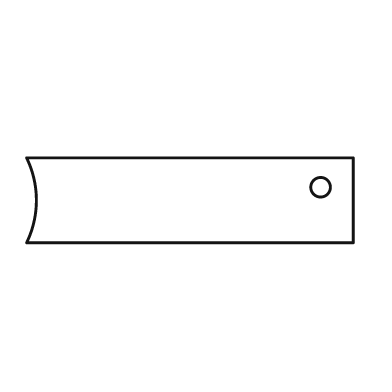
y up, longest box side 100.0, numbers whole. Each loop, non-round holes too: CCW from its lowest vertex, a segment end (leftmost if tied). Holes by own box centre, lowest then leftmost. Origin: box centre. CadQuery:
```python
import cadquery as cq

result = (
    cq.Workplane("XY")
    .moveTo(-50.0, -13.0)
    .lineTo(50.0, -13.0)
    .lineTo(50.0, 13.0)
    .lineTo(-50.0, 13.0)
    .threePointArc((-47.0, 0.0), (-50.0, -13.0))
    .close()
    .moveTo(40.0, 4.0)
    .circle(3.0)
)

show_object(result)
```